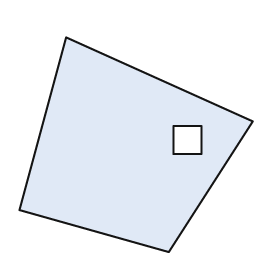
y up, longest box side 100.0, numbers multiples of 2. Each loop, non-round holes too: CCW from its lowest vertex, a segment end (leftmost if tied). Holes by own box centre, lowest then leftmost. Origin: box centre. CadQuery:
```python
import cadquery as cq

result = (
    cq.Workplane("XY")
    .moveTo(14.0, -46.0)
    .lineTo(50.0, 10.0)
    .lineTo(-30.0, 46.0)
    .lineTo(-50.0, -28.0)
    .close()
    .moveTo(16.0, -4.0)
    .lineTo(28.0, -4.0)
    .lineTo(28.0, 8.0)
    .lineTo(16.0, 8.0)
    .close()
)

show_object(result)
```